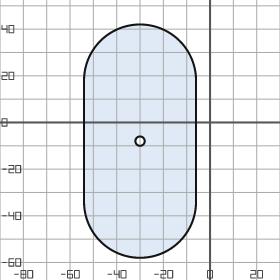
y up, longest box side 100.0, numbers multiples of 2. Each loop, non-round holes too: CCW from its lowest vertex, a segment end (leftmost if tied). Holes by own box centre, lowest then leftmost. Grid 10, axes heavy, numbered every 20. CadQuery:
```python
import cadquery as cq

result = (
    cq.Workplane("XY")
    .moveTo(-54.0, -34.0)
    .threePointArc((-30.0, -58.0), (-6.0, -34.0))
    .lineTo(-6.0, 18.0)
    .threePointArc((-30.0, 42.0), (-54.0, 18.0))
    .close()
    .moveTo(-30.0, -8.0)
    .circle(2.0)
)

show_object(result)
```